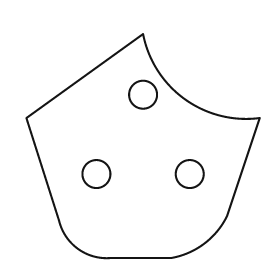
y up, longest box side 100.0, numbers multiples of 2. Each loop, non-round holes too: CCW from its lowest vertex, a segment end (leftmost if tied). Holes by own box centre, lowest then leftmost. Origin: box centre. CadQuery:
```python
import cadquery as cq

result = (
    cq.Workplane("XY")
    .moveTo(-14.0, -48.0)
    .lineTo(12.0, -48.0)
    .threePointArc((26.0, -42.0), (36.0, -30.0))
    .lineTo(50.0, 12.0)
    .threePointArc((18.0, 20.0), (0.0, 48.0))
    .lineTo(-50.0, 12.0)
    .lineTo(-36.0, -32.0)
    .threePointArc((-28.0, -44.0), (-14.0, -48.0))
    .close()
    .moveTo(-20.0, -12.0)
    .circle(6.0)
    .moveTo(20.0, -12.0)
    .circle(6.0)
    .moveTo(0.0, 22.0)
    .circle(6.0)
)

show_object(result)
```